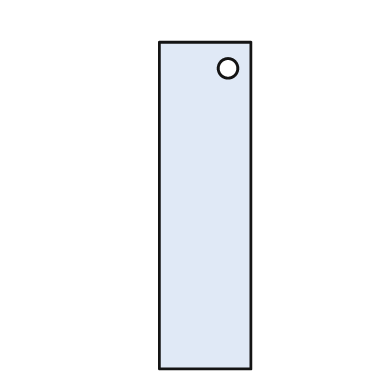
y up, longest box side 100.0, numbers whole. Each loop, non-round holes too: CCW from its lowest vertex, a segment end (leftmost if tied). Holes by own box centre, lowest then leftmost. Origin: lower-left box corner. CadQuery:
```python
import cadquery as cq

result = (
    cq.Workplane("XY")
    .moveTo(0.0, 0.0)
    .lineTo(28.0, 0.0)
    .lineTo(28.0, 100.0)
    .lineTo(0.0, 100.0)
    .close()
    .moveTo(21.0, 92.0)
    .circle(3.0)
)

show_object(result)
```